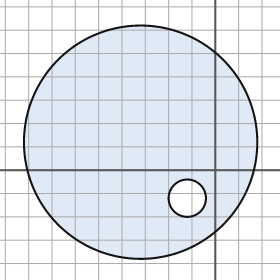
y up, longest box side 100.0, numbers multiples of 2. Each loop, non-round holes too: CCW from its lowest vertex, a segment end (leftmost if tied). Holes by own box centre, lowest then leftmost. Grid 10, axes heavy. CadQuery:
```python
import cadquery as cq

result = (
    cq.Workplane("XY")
    .moveTo(-32.0, 12.0)
    .circle(50.0)
    .moveTo(-12.0, -12.0)
    .circle(8.0)
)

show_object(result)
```